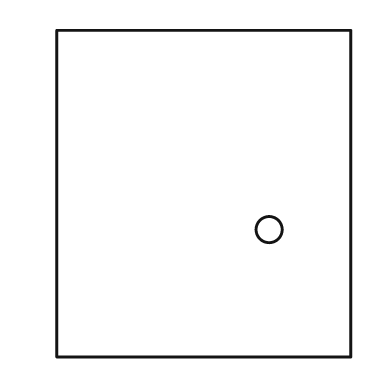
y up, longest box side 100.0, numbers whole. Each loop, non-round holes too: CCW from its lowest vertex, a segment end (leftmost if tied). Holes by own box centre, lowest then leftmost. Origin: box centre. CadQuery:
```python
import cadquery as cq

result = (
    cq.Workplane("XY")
    .moveTo(-45.0, -50.0)
    .lineTo(45.0, -50.0)
    .lineTo(45.0, 50.0)
    .lineTo(-45.0, 50.0)
    .close()
    .moveTo(20.0, -11.0)
    .circle(4.0)
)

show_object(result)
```